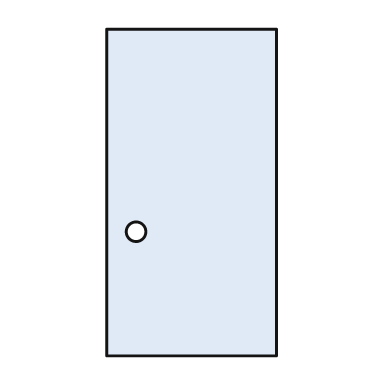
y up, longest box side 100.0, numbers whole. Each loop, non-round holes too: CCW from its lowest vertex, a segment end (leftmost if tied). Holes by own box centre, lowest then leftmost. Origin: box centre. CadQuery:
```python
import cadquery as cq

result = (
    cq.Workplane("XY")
    .moveTo(-26.0, -50.0)
    .lineTo(26.0, -50.0)
    .lineTo(26.0, 50.0)
    .lineTo(-26.0, 50.0)
    .close()
    .moveTo(-17.0, -12.0)
    .circle(3.0)
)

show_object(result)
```